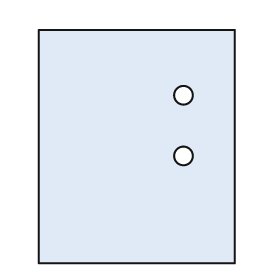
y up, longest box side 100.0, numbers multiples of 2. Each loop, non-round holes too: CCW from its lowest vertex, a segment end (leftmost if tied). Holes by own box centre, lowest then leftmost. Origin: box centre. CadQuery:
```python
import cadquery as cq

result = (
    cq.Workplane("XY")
    .moveTo(-42.0, -50.0)
    .lineTo(42.0, -50.0)
    .lineTo(42.0, 50.0)
    .lineTo(-42.0, 50.0)
    .close()
    .moveTo(20.0, -4.0)
    .circle(4.0)
    .moveTo(20.0, 22.0)
    .circle(4.0)
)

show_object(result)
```